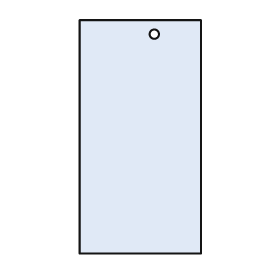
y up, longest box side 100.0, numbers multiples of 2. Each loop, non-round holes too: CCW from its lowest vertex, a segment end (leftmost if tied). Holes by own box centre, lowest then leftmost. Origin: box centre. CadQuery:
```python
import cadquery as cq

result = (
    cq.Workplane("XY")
    .moveTo(-26.0, -50.0)
    .lineTo(26.0, -50.0)
    .lineTo(26.0, 50.0)
    .lineTo(-26.0, 50.0)
    .close()
    .moveTo(6.0, 44.0)
    .circle(2.0)
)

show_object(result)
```